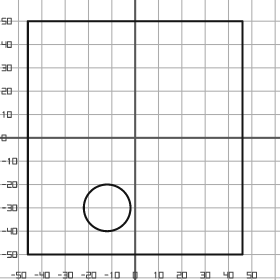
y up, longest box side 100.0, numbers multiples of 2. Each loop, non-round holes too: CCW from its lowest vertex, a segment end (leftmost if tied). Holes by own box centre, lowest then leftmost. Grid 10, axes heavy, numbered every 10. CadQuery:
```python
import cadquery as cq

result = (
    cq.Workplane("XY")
    .moveTo(-46.0, -50.0)
    .lineTo(46.0, -50.0)
    .lineTo(46.0, 50.0)
    .lineTo(-46.0, 50.0)
    .close()
    .moveTo(-12.0, -30.0)
    .circle(10.0)
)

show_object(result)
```